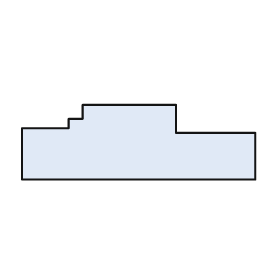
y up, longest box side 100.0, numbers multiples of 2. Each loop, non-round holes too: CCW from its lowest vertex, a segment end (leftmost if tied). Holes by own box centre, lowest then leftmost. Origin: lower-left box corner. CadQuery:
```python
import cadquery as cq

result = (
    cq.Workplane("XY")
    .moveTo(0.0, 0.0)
    .lineTo(100.0, 0.0)
    .lineTo(100.0, 20.0)
    .lineTo(66.0, 20.0)
    .lineTo(66.0, 32.0)
    .lineTo(26.0, 32.0)
    .lineTo(26.0, 26.0)
    .lineTo(20.0, 26.0)
    .lineTo(20.0, 22.0)
    .lineTo(0.0, 22.0)
    .close()
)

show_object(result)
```